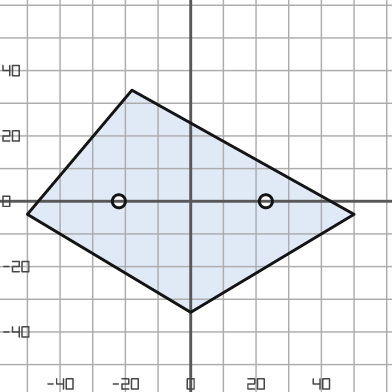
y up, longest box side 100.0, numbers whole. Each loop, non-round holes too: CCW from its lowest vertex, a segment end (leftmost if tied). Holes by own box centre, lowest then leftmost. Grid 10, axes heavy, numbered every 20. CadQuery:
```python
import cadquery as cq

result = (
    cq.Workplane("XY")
    .moveTo(0.0, -34.0)
    .lineTo(50.0, -4.0)
    .lineTo(-18.0, 34.0)
    .lineTo(-50.0, -4.0)
    .close()
    .moveTo(-22.0, 0.0)
    .circle(2.0)
    .moveTo(23.0, 0.0)
    .circle(2.0)
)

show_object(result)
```